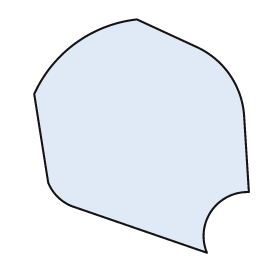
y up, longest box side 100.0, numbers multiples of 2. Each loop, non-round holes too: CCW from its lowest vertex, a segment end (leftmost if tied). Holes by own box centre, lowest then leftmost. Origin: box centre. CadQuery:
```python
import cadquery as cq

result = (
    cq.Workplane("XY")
    .moveTo(28.0, -50.0)
    .threePointArc((30.0, -32.0), (46.0, -24.0))
    .lineTo(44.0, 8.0)
    .threePointArc((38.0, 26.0), (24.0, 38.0))
    .lineTo(-2.0, 50.0)
    .threePointArc((-28.0, 40.0), (-46.0, 18.0))
    .lineTo(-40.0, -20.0)
    .threePointArc((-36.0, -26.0), (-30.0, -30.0))
    .close()
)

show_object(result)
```